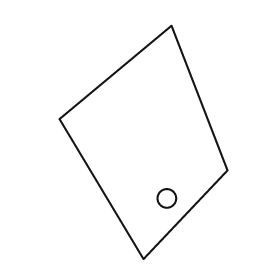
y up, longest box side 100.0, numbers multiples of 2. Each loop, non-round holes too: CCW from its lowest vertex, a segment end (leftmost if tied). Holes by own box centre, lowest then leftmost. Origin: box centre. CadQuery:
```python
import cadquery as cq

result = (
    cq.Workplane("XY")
    .moveTo(0.0, -50.0)
    .lineTo(36.0, -12.0)
    .lineTo(12.0, 50.0)
    .lineTo(-36.0, 10.0)
    .close()
    .moveTo(10.0, -24.0)
    .circle(4.0)
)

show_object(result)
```